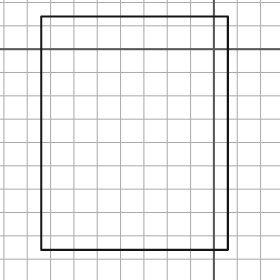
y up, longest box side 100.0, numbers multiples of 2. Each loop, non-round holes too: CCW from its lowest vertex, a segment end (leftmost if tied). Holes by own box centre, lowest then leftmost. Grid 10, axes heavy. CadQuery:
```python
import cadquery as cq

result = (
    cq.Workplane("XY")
    .moveTo(-74.0, -86.0)
    .lineTo(6.0, -86.0)
    .lineTo(6.0, 14.0)
    .lineTo(-74.0, 14.0)
    .close()
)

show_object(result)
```